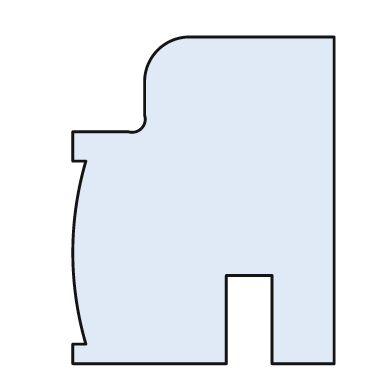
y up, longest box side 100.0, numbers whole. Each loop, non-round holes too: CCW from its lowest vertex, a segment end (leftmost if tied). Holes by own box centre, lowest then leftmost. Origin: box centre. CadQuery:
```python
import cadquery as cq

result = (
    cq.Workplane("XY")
    .moveTo(-40.0, -50.0)
    .lineTo(7.0, -50.0)
    .lineTo(7.0, -23.0)
    .lineTo(21.0, -23.0)
    .lineTo(21.0, -50.0)
    .lineTo(40.0, -50.0)
    .lineTo(40.0, 50.0)
    .lineTo(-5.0, 50.0)
    .threePointArc((-14.0, 46.0), (-18.0, 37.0))
    .lineTo(-18.0, 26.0)
    .threePointArc((-19.0, 22.0), (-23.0, 21.0))
    .lineTo(-40.0, 21.0)
    .lineTo(-40.0, 12.0)
    .lineTo(-36.0, 12.0)
    .threePointArc((-40.0, -16.0), (-36.0, -44.0))
    .lineTo(-40.0, -44.0)
    .close()
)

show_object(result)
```